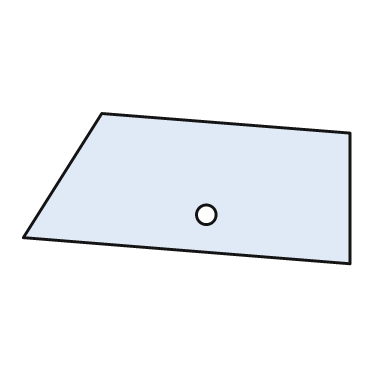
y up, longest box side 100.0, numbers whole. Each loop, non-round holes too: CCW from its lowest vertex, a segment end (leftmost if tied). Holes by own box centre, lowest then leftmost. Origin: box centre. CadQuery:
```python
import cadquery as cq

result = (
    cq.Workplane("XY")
    .moveTo(50.0, -23.0)
    .lineTo(50.0, 17.0)
    .lineTo(-26.0, 23.0)
    .lineTo(-50.0, -15.0)
    .close()
    .moveTo(6.0, -8.0)
    .circle(3.0)
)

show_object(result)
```